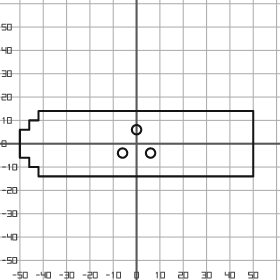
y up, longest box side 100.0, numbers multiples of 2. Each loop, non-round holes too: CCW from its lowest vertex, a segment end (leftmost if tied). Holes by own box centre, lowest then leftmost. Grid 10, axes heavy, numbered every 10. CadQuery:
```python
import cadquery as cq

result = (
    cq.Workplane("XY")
    .moveTo(-42.0, -14.0)
    .lineTo(50.0, -14.0)
    .lineTo(50.0, 14.0)
    .lineTo(-42.0, 14.0)
    .lineTo(-42.0, 10.0)
    .lineTo(-46.0, 10.0)
    .lineTo(-46.0, 6.0)
    .lineTo(-50.0, 6.0)
    .lineTo(-50.0, -6.0)
    .lineTo(-46.0, -6.0)
    .lineTo(-46.0, -10.0)
    .lineTo(-42.0, -10.0)
    .close()
    .moveTo(-6.0, -4.0)
    .circle(2.0)
    .moveTo(6.0, -4.0)
    .circle(2.0)
    .moveTo(0.0, 6.0)
    .circle(2.0)
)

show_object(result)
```